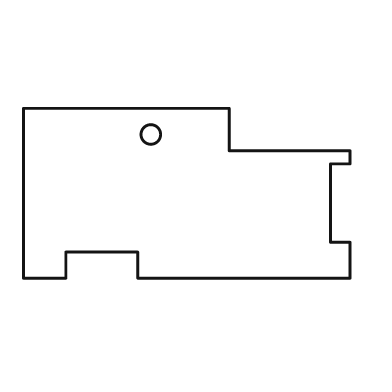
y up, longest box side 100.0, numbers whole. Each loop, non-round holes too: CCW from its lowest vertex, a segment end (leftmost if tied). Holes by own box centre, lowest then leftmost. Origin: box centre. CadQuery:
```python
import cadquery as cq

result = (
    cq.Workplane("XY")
    .moveTo(-50.0, -26.0)
    .lineTo(-37.0, -26.0)
    .lineTo(-37.0, -18.0)
    .lineTo(-15.0, -18.0)
    .lineTo(-15.0, -26.0)
    .lineTo(50.0, -26.0)
    .lineTo(50.0, -15.0)
    .lineTo(44.0, -15.0)
    .lineTo(44.0, 9.0)
    .lineTo(50.0, 9.0)
    .lineTo(50.0, 13.0)
    .lineTo(13.0, 13.0)
    .lineTo(13.0, 26.0)
    .lineTo(-50.0, 26.0)
    .close()
    .moveTo(-11.0, 18.0)
    .circle(3.0)
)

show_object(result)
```